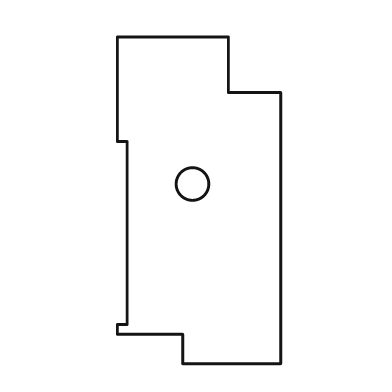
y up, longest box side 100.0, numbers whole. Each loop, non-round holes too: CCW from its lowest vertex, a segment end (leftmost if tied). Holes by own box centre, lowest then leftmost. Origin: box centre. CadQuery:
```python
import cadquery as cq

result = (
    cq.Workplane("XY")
    .moveTo(-5.0, -50.0)
    .lineTo(25.0, -50.0)
    .lineTo(25.0, 33.0)
    .lineTo(9.0, 33.0)
    .lineTo(9.0, 50.0)
    .lineTo(-25.0, 50.0)
    .lineTo(-25.0, 18.0)
    .lineTo(-22.0, 18.0)
    .lineTo(-22.0, -38.0)
    .lineTo(-25.0, -38.0)
    .lineTo(-25.0, -41.0)
    .lineTo(-5.0, -41.0)
    .close()
    .moveTo(-2.0, 5.0)
    .circle(5.0)
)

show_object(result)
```